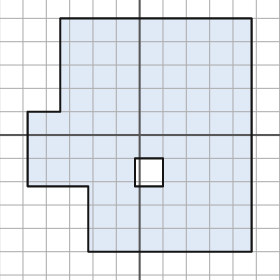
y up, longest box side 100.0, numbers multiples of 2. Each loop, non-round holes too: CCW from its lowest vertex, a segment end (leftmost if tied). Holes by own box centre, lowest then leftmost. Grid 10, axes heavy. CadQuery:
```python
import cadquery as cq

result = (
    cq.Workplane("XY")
    .moveTo(-22.0, -50.0)
    .lineTo(48.0, -50.0)
    .lineTo(48.0, 50.0)
    .lineTo(-34.0, 50.0)
    .lineTo(-34.0, 10.0)
    .lineTo(-48.0, 10.0)
    .lineTo(-48.0, -22.0)
    .lineTo(-22.0, -22.0)
    .close()
    .moveTo(-2.0, -22.0)
    .lineTo(10.0, -22.0)
    .lineTo(10.0, -10.0)
    .lineTo(-2.0, -10.0)
    .close()
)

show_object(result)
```